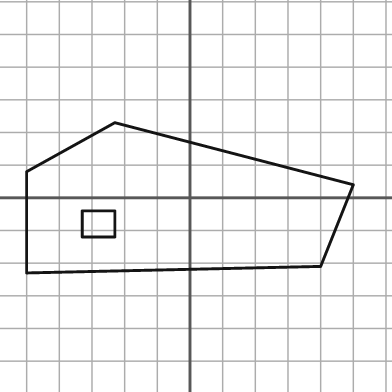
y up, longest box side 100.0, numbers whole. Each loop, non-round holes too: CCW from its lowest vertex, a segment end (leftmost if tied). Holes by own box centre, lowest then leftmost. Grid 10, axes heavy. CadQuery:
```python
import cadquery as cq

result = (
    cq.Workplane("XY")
    .moveTo(-50.0, -23.0)
    .lineTo(40.0, -21.0)
    .lineTo(50.0, 4.0)
    .lineTo(-23.0, 23.0)
    .lineTo(-50.0, 8.0)
    .close()
    .moveTo(-33.0, -12.0)
    .lineTo(-23.0, -12.0)
    .lineTo(-23.0, -4.0)
    .lineTo(-33.0, -4.0)
    .close()
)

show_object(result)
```